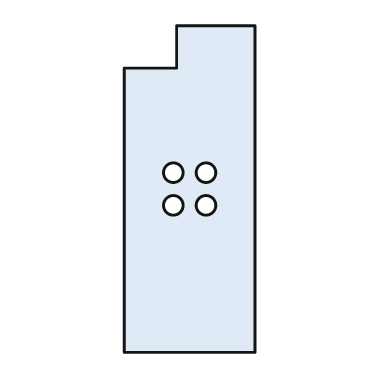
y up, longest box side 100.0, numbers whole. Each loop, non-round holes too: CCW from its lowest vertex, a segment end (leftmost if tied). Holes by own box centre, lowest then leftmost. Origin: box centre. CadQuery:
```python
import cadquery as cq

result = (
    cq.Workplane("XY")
    .moveTo(-20.0, -50.0)
    .lineTo(20.0, -50.0)
    .lineTo(20.0, 50.0)
    .lineTo(-4.0, 50.0)
    .lineTo(-4.0, 37.0)
    .lineTo(-20.0, 37.0)
    .close()
    .moveTo(-5.0, -5.0)
    .circle(3.0)
    .moveTo(5.0, -5.0)
    .circle(3.0)
    .moveTo(-5.0, 5.0)
    .circle(3.0)
    .moveTo(5.0, 5.0)
    .circle(3.0)
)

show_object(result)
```